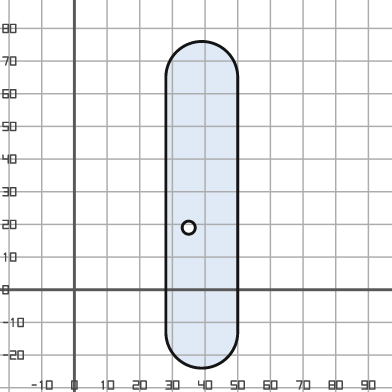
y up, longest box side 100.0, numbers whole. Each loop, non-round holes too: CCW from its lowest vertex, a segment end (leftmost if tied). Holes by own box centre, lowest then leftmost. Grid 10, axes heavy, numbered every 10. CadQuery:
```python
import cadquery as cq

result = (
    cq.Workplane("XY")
    .moveTo(28.0, -13.0)
    .threePointArc((39.0, -24.0), (50.0, -13.0))
    .lineTo(50.0, 65.0)
    .threePointArc((39.0, 76.0), (28.0, 65.0))
    .close()
    .moveTo(35.0, 19.0)
    .circle(2.0)
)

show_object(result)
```